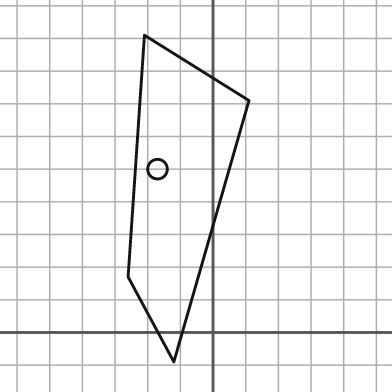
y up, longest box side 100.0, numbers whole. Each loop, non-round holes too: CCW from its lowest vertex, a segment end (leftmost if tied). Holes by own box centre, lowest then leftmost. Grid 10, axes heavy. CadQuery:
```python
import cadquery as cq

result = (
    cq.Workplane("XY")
    .moveTo(-12.0, -9.0)
    .lineTo(11.0, 71.0)
    .lineTo(-21.0, 91.0)
    .lineTo(-26.0, 17.0)
    .close()
    .moveTo(-17.0, 50.0)
    .circle(3.0)
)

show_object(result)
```